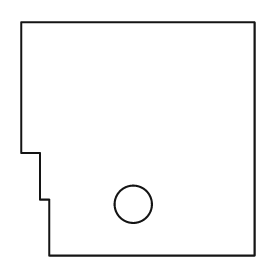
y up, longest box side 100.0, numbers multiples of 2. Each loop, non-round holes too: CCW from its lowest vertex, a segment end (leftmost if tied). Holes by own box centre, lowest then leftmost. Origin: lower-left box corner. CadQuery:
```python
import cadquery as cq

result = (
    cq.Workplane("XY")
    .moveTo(12.0, 0.0)
    .lineTo(100.0, 0.0)
    .lineTo(100.0, 100.0)
    .lineTo(0.0, 100.0)
    .lineTo(0.0, 44.0)
    .lineTo(8.0, 44.0)
    .lineTo(8.0, 24.0)
    .lineTo(12.0, 24.0)
    .close()
    .moveTo(48.0, 22.0)
    .circle(8.0)
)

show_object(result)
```